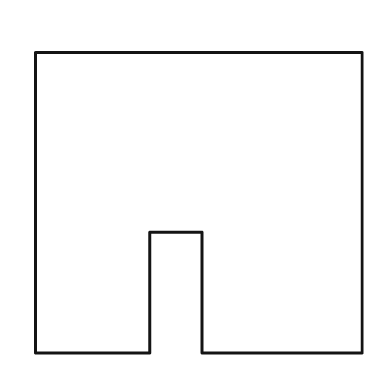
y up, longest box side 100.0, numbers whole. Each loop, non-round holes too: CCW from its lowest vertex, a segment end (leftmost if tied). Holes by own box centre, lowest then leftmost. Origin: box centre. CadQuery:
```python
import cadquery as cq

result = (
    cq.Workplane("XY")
    .moveTo(-50.0, -46.0)
    .lineTo(-15.0, -46.0)
    .lineTo(-15.0, -9.0)
    .lineTo(1.0, -9.0)
    .lineTo(1.0, -46.0)
    .lineTo(50.0, -46.0)
    .lineTo(50.0, 46.0)
    .lineTo(-50.0, 46.0)
    .close()
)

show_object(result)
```